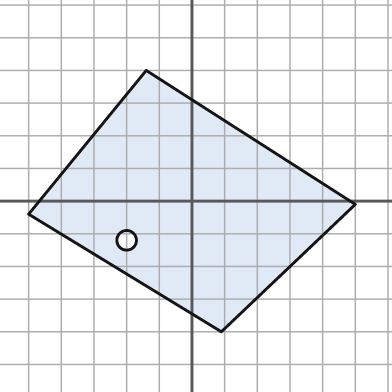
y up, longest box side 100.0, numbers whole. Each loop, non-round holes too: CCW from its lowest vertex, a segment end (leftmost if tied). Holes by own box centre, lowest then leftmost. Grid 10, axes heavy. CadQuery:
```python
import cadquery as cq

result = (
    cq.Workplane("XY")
    .moveTo(9.0, -40.0)
    .lineTo(50.0, -1.0)
    .lineTo(-14.0, 40.0)
    .lineTo(-50.0, -4.0)
    .close()
    .moveTo(-20.0, -12.0)
    .circle(3.0)
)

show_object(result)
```